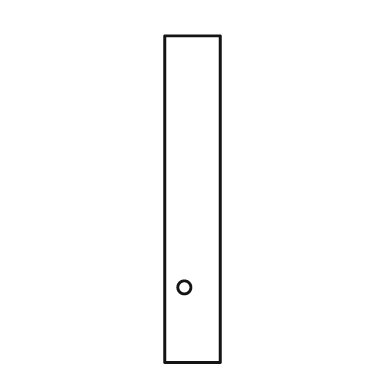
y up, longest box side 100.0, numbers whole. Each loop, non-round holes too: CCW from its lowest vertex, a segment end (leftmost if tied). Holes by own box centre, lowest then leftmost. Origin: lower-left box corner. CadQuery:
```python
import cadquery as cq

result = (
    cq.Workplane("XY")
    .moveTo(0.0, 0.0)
    .lineTo(17.0, 0.0)
    .lineTo(17.0, 100.0)
    .lineTo(0.0, 100.0)
    .close()
    .moveTo(6.0, 23.0)
    .circle(2.0)
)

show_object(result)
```